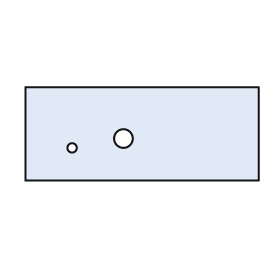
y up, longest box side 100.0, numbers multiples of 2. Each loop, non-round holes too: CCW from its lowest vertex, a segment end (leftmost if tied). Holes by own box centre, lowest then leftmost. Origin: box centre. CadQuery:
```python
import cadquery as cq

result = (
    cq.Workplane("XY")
    .moveTo(-50.0, -20.0)
    .lineTo(50.0, -20.0)
    .lineTo(50.0, 20.0)
    .lineTo(-50.0, 20.0)
    .close()
    .moveTo(-30.0, -6.0)
    .circle(2.0)
    .moveTo(-8.0, -2.0)
    .circle(4.0)
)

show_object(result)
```